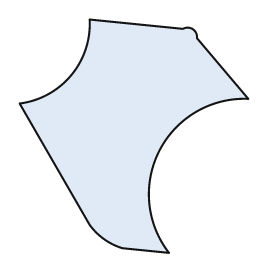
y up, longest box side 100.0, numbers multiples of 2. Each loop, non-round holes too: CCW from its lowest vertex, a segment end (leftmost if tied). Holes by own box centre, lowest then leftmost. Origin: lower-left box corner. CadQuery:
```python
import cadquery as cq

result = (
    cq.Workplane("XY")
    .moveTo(64.0, 0.0)
    .threePointArc((60.0, 44.0), (98.0, 66.0))
    .lineTo(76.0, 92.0)
    .threePointArc((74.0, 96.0), (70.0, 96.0))
    .lineTo(30.0, 100.0)
    .threePointArc((22.0, 76.0), (0.0, 64.0))
    .lineTo(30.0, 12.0)
    .threePointArc((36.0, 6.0), (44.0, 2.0))
    .close()
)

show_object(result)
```